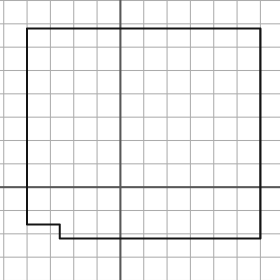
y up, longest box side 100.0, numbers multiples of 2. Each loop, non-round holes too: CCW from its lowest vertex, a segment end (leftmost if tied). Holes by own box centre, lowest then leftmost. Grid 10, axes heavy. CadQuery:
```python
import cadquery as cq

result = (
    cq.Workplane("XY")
    .moveTo(-26.0, -22.0)
    .lineTo(60.0, -22.0)
    .lineTo(60.0, 68.0)
    .lineTo(-40.0, 68.0)
    .lineTo(-40.0, -16.0)
    .lineTo(-26.0, -16.0)
    .close()
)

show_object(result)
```